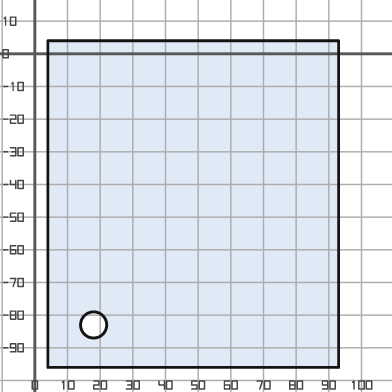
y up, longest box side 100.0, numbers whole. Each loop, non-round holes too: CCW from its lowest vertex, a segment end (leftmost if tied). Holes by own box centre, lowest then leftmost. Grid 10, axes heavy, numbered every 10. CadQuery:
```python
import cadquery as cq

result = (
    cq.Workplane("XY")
    .moveTo(4.0, -96.0)
    .lineTo(93.0, -96.0)
    .lineTo(93.0, 4.0)
    .lineTo(4.0, 4.0)
    .close()
    .moveTo(18.0, -83.0)
    .circle(4.0)
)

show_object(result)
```